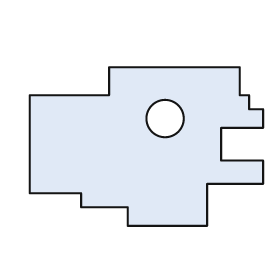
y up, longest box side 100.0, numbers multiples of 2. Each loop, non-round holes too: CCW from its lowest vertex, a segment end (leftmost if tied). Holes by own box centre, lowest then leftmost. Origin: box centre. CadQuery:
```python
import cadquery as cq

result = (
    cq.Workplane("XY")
    .moveTo(-8.0, -34.0)
    .lineTo(26.0, -34.0)
    .lineTo(26.0, -16.0)
    .lineTo(50.0, -16.0)
    .lineTo(50.0, -6.0)
    .lineTo(32.0, -6.0)
    .lineTo(32.0, 8.0)
    .lineTo(50.0, 8.0)
    .lineTo(50.0, 16.0)
    .lineTo(44.0, 16.0)
    .lineTo(44.0, 22.0)
    .lineTo(40.0, 22.0)
    .lineTo(40.0, 34.0)
    .lineTo(-16.0, 34.0)
    .lineTo(-16.0, 22.0)
    .lineTo(-50.0, 22.0)
    .lineTo(-50.0, -20.0)
    .lineTo(-28.0, -20.0)
    .lineTo(-28.0, -26.0)
    .lineTo(-8.0, -26.0)
    .close()
    .moveTo(8.0, 12.0)
    .circle(8.0)
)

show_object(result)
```